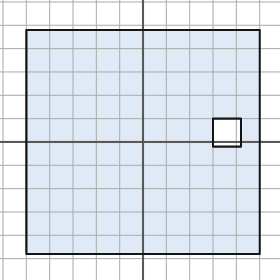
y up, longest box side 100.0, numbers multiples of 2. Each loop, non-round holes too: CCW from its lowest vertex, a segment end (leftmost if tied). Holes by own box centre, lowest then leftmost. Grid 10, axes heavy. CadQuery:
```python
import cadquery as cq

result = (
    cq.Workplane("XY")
    .moveTo(-50.0, -48.0)
    .lineTo(50.0, -48.0)
    .lineTo(50.0, 48.0)
    .lineTo(-50.0, 48.0)
    .close()
    .moveTo(30.0, -2.0)
    .lineTo(42.0, -2.0)
    .lineTo(42.0, 10.0)
    .lineTo(30.0, 10.0)
    .close()
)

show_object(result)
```